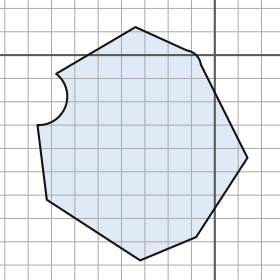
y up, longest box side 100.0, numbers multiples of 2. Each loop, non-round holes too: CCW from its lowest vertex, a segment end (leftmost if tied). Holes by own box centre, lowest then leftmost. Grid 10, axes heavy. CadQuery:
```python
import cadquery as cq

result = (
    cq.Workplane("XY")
    .moveTo(-32.0, -88.0)
    .lineTo(-8.0, -78.0)
    .lineTo(14.0, -44.0)
    .lineTo(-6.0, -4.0)
    .threePointArc((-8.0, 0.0), (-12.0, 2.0))
    .lineTo(-34.0, 12.0)
    .lineTo(-68.0, -8.0)
    .threePointArc((-64.0, -22.0), (-76.0, -30.0))
    .lineTo(-72.0, -62.0)
    .close()
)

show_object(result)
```